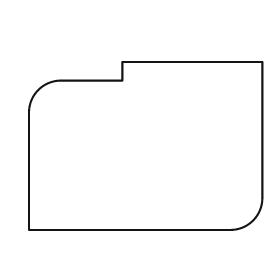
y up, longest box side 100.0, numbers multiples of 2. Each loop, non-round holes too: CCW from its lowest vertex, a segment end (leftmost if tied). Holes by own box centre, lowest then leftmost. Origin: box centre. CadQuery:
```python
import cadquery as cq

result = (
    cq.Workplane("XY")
    .moveTo(-50.0, -36.0)
    .lineTo(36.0, -36.0)
    .threePointArc((46.0, -32.0), (50.0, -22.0))
    .lineTo(50.0, 36.0)
    .lineTo(-10.0, 36.0)
    .lineTo(-10.0, 28.0)
    .lineTo(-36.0, 28.0)
    .threePointArc((-46.0, 24.0), (-50.0, 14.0))
    .close()
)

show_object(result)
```